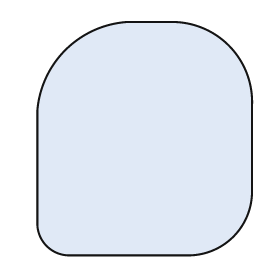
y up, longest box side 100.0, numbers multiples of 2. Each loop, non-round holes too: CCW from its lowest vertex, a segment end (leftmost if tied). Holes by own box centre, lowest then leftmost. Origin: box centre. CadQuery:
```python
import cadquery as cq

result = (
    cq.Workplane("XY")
    .moveTo(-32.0, -50.0)
    .lineTo(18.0, -50.0)
    .threePointArc((38.0, -42.0), (46.0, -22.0))
    .lineTo(46.0, 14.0)
    .threePointArc((36.0, 40.0), (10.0, 50.0))
    .lineTo(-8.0, 50.0)
    .threePointArc((-34.0, 38.0), (-46.0, 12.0))
    .lineTo(-46.0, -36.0)
    .threePointArc((-42.0, -46.0), (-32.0, -50.0))
    .close()
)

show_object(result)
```